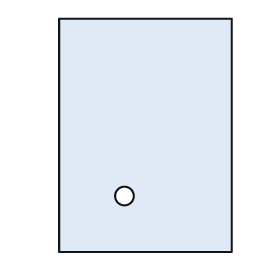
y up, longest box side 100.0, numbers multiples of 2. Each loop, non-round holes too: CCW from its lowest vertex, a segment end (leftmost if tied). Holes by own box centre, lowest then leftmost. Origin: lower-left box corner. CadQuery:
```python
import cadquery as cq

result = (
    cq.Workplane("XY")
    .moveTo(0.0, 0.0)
    .lineTo(74.0, 0.0)
    .lineTo(74.0, 100.0)
    .lineTo(0.0, 100.0)
    .close()
    .moveTo(28.0, 24.0)
    .circle(4.0)
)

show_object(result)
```